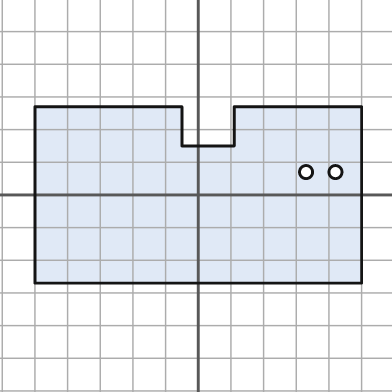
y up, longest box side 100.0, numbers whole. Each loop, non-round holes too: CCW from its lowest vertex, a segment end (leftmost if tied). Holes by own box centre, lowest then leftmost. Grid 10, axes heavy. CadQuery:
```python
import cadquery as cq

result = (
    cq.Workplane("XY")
    .moveTo(-50.0, -27.0)
    .lineTo(50.0, -27.0)
    .lineTo(50.0, 27.0)
    .lineTo(11.0, 27.0)
    .lineTo(11.0, 15.0)
    .lineTo(-5.0, 15.0)
    .lineTo(-5.0, 27.0)
    .lineTo(-50.0, 27.0)
    .close()
    .moveTo(33.0, 7.0)
    .circle(2.0)
    .moveTo(42.0, 7.0)
    .circle(2.0)
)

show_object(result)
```